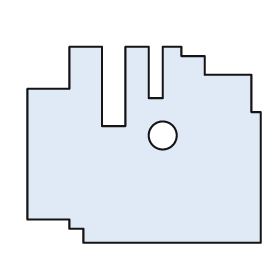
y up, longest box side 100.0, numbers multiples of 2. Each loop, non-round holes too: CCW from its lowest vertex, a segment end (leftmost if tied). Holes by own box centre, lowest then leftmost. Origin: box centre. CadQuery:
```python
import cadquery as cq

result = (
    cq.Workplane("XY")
    .moveTo(-26.0, -42.0)
    .lineTo(50.0, -42.0)
    .lineTo(50.0, 14.0)
    .lineTo(46.0, 14.0)
    .lineTo(46.0, 30.0)
    .lineTo(26.0, 30.0)
    .lineTo(26.0, 38.0)
    .lineTo(16.0, 38.0)
    .lineTo(16.0, 42.0)
    .lineTo(8.0, 42.0)
    .lineTo(8.0, 20.0)
    .lineTo(2.0, 20.0)
    .lineTo(2.0, 42.0)
    .lineTo(-8.0, 42.0)
    .lineTo(-8.0, 8.0)
    .lineTo(-18.0, 8.0)
    .lineTo(-18.0, 42.0)
    .lineTo(-32.0, 42.0)
    .lineTo(-32.0, 24.0)
    .lineTo(-50.0, 24.0)
    .lineTo(-50.0, -32.0)
    .lineTo(-32.0, -32.0)
    .lineTo(-32.0, -36.0)
    .lineTo(-26.0, -36.0)
    .close()
    .moveTo(8.0, 4.0)
    .circle(6.0)
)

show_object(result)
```